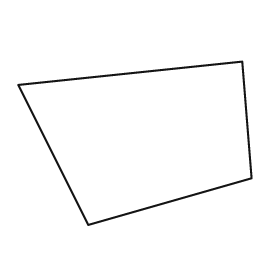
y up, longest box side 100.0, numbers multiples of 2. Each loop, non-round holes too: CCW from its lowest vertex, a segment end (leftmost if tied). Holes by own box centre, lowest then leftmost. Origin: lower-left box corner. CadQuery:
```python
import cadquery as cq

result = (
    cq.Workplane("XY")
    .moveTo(30.0, 0.0)
    .lineTo(100.0, 20.0)
    .lineTo(96.0, 70.0)
    .lineTo(0.0, 60.0)
    .close()
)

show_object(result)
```